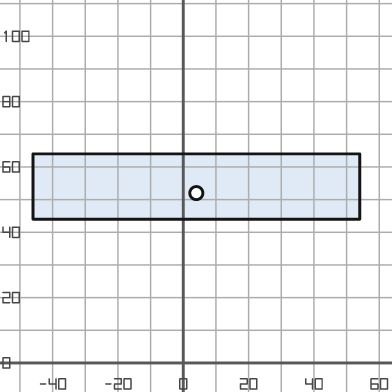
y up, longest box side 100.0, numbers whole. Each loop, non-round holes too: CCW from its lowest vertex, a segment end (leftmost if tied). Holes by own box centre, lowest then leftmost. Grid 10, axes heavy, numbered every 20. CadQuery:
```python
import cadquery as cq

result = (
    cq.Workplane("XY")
    .moveTo(-46.0, 44.0)
    .lineTo(54.0, 44.0)
    .lineTo(54.0, 64.0)
    .lineTo(-46.0, 64.0)
    .close()
    .moveTo(4.0, 52.0)
    .circle(2.0)
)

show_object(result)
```